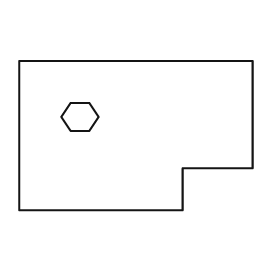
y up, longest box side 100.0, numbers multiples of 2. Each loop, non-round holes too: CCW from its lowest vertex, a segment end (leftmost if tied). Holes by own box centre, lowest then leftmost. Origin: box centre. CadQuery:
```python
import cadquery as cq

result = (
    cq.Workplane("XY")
    .moveTo(-50.0, -32.0)
    .lineTo(20.0, -32.0)
    .lineTo(20.0, -14.0)
    .lineTo(50.0, -14.0)
    .lineTo(50.0, 32.0)
    .lineTo(-50.0, 32.0)
    .close()
    .moveTo(-28.0, 2.0)
    .lineTo(-20.0, 2.0)
    .lineTo(-16.0, 8.0)
    .lineTo(-20.0, 14.0)
    .lineTo(-28.0, 14.0)
    .lineTo(-32.0, 8.0)
    .close()
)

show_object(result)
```